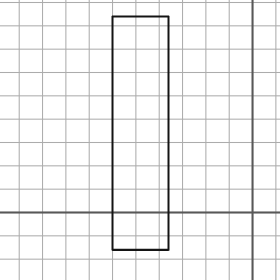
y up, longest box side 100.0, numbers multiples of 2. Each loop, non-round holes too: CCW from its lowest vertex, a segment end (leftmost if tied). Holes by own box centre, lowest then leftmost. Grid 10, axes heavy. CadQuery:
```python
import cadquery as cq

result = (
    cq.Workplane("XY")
    .moveTo(-60.0, -16.0)
    .lineTo(-36.0, -16.0)
    .lineTo(-36.0, 84.0)
    .lineTo(-60.0, 84.0)
    .close()
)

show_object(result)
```